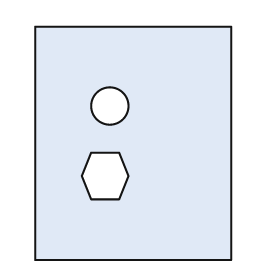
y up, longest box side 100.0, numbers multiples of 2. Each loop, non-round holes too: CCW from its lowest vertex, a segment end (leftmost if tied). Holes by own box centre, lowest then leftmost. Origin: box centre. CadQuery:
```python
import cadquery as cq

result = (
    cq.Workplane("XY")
    .moveTo(-42.0, -50.0)
    .lineTo(42.0, -50.0)
    .lineTo(42.0, 50.0)
    .lineTo(-42.0, 50.0)
    .close()
    .moveTo(-18.0, -24.0)
    .lineTo(-6.0, -24.0)
    .lineTo(-2.0, -14.0)
    .lineTo(-6.0, -4.0)
    .lineTo(-18.0, -4.0)
    .lineTo(-22.0, -14.0)
    .close()
    .moveTo(-10.0, 16.0)
    .circle(8.0)
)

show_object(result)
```